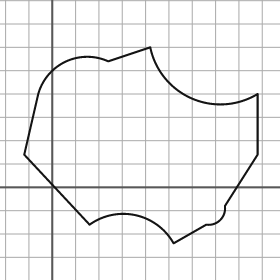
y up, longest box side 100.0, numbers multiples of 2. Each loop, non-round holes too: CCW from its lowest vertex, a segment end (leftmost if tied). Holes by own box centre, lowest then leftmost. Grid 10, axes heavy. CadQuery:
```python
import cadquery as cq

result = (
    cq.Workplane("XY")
    .moveTo(52.0, -24.0)
    .lineTo(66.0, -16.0)
    .threePointArc((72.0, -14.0), (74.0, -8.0))
    .lineTo(88.0, 14.0)
    .lineTo(88.0, 40.0)
    .threePointArc((60.0, 38.0), (42.0, 60.0))
    .lineTo(24.0, 54.0)
    .threePointArc((6.0, 54.0), (-6.0, 40.0))
    .lineTo(-12.0, 14.0)
    .lineTo(16.0, -16.0)
    .threePointArc((36.0, -12.0), (52.0, -24.0))
    .close()
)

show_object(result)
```